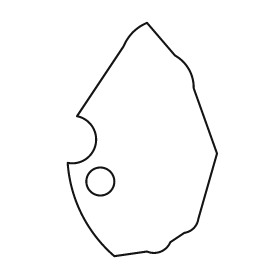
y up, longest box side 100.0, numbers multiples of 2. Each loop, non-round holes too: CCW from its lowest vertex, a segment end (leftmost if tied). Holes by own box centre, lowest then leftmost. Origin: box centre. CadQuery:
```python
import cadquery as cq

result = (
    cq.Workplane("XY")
    .moveTo(-12.0, -50.0)
    .lineTo(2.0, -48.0)
    .threePointArc((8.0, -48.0), (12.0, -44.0))
    .lineTo(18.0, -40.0)
    .threePointArc((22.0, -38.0), (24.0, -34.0))
    .lineTo(32.0, -6.0)
    .lineTo(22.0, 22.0)
    .threePointArc((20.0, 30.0), (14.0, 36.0))
    .lineTo(2.0, 50.0)
    .threePointArc((-4.0, 46.0), (-8.0, 40.0))
    .lineTo(-28.0, 10.0)
    .threePointArc((-20.0, -2.0), (-32.0, -10.0))
    .threePointArc((-26.0, -32.0), (-12.0, -50.0))
    .close()
    .moveTo(-18.0, -18.0)
    .circle(6.0)
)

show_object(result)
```